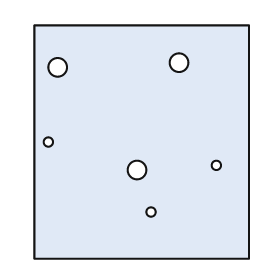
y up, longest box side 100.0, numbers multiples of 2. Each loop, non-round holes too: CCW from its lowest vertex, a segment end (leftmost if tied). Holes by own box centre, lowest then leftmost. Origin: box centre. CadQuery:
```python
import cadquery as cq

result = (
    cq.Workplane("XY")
    .moveTo(-46.0, -50.0)
    .lineTo(46.0, -50.0)
    .lineTo(46.0, 50.0)
    .lineTo(-46.0, 50.0)
    .close()
    .moveTo(4.0, -30.0)
    .circle(2.0)
    .moveTo(-2.0, -12.0)
    .circle(4.0)
    .moveTo(32.0, -10.0)
    .circle(2.0)
    .moveTo(-40.0, 0.0)
    .circle(2.0)
    .moveTo(-36.0, 32.0)
    .circle(4.0)
    .moveTo(16.0, 34.0)
    .circle(4.0)
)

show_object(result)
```